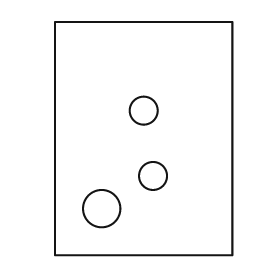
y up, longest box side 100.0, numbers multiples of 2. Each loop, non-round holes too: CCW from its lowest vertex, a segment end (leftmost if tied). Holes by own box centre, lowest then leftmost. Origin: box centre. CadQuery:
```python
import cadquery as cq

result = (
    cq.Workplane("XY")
    .moveTo(-38.0, -50.0)
    .lineTo(38.0, -50.0)
    .lineTo(38.0, 50.0)
    .lineTo(-38.0, 50.0)
    .close()
    .moveTo(-18.0, -30.0)
    .circle(8.0)
    .moveTo(4.0, -16.0)
    .circle(6.0)
    .moveTo(0.0, 12.0)
    .circle(6.0)
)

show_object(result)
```